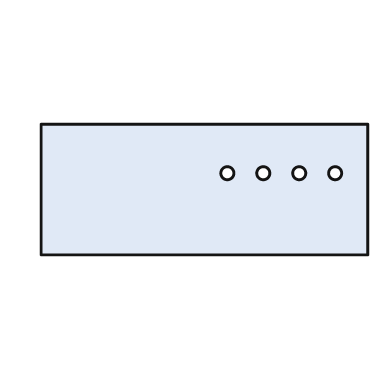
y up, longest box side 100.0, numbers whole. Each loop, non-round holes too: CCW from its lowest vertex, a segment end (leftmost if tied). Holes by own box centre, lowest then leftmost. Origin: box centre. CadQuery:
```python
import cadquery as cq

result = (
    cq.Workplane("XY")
    .moveTo(-50.0, -20.0)
    .lineTo(50.0, -20.0)
    .lineTo(50.0, 20.0)
    .lineTo(-50.0, 20.0)
    .close()
    .moveTo(7.0, 5.0)
    .circle(2.0)
    .moveTo(18.0, 5.0)
    .circle(2.0)
    .moveTo(29.0, 5.0)
    .circle(2.0)
    .moveTo(40.0, 5.0)
    .circle(2.0)
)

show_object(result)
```